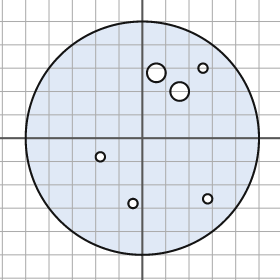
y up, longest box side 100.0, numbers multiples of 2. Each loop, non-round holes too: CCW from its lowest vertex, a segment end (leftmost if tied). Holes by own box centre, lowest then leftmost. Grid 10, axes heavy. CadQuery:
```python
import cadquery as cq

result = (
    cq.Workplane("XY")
    .moveTo(0.0, 0.0)
    .circle(50.0)
    .moveTo(-4.0, -28.0)
    .circle(2.0)
    .moveTo(28.0, -26.0)
    .circle(2.0)
    .moveTo(-18.0, -8.0)
    .circle(2.0)
    .moveTo(16.0, 20.0)
    .circle(4.0)
    .moveTo(6.0, 28.0)
    .circle(4.0)
    .moveTo(26.0, 30.0)
    .circle(2.0)
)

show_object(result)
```